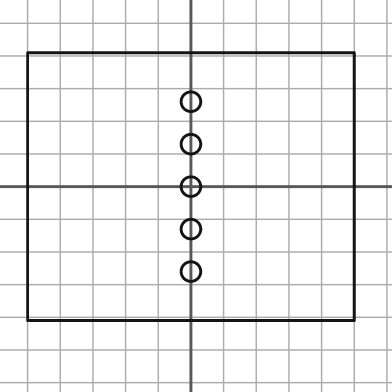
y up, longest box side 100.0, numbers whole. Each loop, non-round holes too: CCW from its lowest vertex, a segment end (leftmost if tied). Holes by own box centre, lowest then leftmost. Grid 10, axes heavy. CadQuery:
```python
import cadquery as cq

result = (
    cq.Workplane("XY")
    .moveTo(-50.0, -41.0)
    .lineTo(50.0, -41.0)
    .lineTo(50.0, 41.0)
    .lineTo(-50.0, 41.0)
    .close()
    .moveTo(0.0, -26.0)
    .circle(3.0)
    .moveTo(0.0, -13.0)
    .circle(3.0)
    .moveTo(0.0, 0.0)
    .circle(3.0)
    .moveTo(0.0, 13.0)
    .circle(3.0)
    .moveTo(0.0, 26.0)
    .circle(3.0)
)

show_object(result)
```